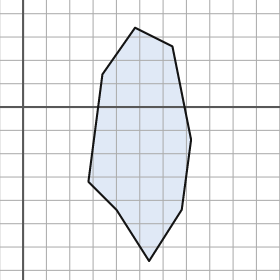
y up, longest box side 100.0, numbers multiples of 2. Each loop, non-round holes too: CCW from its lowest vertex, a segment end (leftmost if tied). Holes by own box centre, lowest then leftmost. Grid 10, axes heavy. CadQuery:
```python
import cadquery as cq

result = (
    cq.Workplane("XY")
    .moveTo(54.0, -66.0)
    .lineTo(68.0, -44.0)
    .lineTo(72.0, -14.0)
    .lineTo(64.0, 26.0)
    .lineTo(48.0, 34.0)
    .lineTo(34.0, 14.0)
    .lineTo(28.0, -32.0)
    .lineTo(40.0, -44.0)
    .close()
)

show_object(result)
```